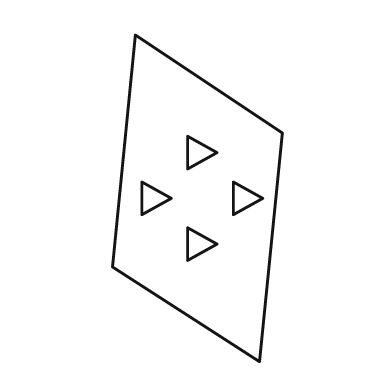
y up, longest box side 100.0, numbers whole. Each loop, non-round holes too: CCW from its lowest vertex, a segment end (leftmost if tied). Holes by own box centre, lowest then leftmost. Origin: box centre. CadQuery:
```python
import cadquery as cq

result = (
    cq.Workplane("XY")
    .moveTo(19.0, -50.0)
    .lineTo(26.0, 20.0)
    .lineTo(-19.0, 50.0)
    .lineTo(-26.0, -21.0)
    .close()
    .moveTo(-3.0, -19.0)
    .lineTo(6.0, -14.0)
    .lineTo(-3.0, -9.0)
    .close()
    .moveTo(-17.0, -5.0)
    .lineTo(-8.0, 0.0)
    .lineTo(-17.0, 5.0)
    .close()
    .moveTo(11.0, -5.0)
    .lineTo(20.0, 0.0)
    .lineTo(11.0, 5.0)
    .close()
    .moveTo(-3.0, 9.0)
    .lineTo(6.0, 14.0)
    .lineTo(-3.0, 19.0)
    .close()
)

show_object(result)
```